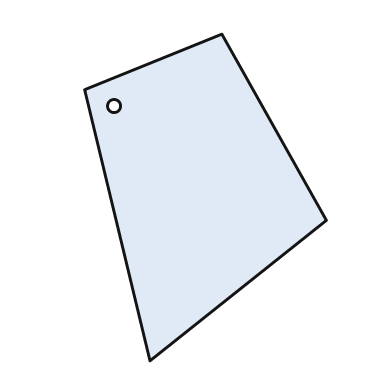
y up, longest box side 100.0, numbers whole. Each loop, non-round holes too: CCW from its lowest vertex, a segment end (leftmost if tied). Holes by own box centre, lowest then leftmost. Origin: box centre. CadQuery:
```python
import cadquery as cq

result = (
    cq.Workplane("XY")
    .moveTo(-17.0, -50.0)
    .lineTo(37.0, -7.0)
    .lineTo(5.0, 50.0)
    .lineTo(-37.0, 33.0)
    .close()
    .moveTo(-28.0, 28.0)
    .circle(2.0)
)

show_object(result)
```